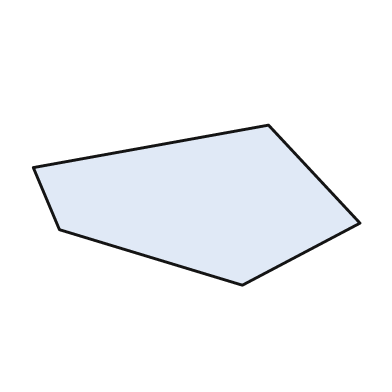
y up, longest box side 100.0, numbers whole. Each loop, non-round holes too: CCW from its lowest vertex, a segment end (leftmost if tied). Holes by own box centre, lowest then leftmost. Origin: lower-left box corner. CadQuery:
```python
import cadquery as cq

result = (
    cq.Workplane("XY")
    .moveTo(64.0, 0.0)
    .lineTo(100.0, 19.0)
    .lineTo(72.0, 49.0)
    .lineTo(0.0, 36.0)
    .lineTo(8.0, 17.0)
    .close()
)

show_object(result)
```